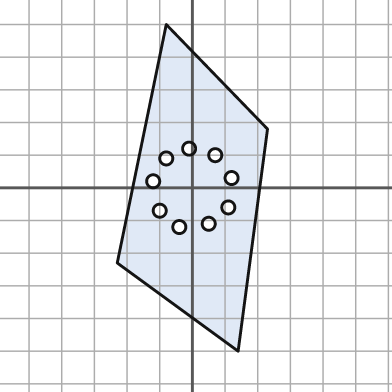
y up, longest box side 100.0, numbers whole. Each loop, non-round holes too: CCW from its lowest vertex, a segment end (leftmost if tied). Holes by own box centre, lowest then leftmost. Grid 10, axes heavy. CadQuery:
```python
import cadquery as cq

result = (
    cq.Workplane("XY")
    .moveTo(14.0, -50.0)
    .lineTo(23.0, 18.0)
    .lineTo(-8.0, 50.0)
    .lineTo(-23.0, -23.0)
    .close()
    .moveTo(-4.0, -12.0)
    .circle(2.0)
    .moveTo(5.0, -11.0)
    .circle(2.0)
    .moveTo(-10.0, -7.0)
    .circle(2.0)
    .moveTo(11.0, -6.0)
    .circle(2.0)
    .moveTo(-12.0, 2.0)
    .circle(2.0)
    .moveTo(12.0, 3.0)
    .circle(2.0)
    .moveTo(-8.0, 9.0)
    .circle(2.0)
    .moveTo(7.0, 10.0)
    .circle(2.0)
    .moveTo(-1.0, 12.0)
    .circle(2.0)
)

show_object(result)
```